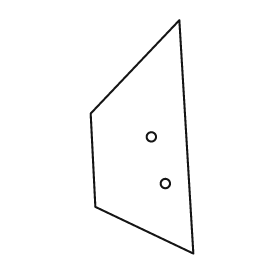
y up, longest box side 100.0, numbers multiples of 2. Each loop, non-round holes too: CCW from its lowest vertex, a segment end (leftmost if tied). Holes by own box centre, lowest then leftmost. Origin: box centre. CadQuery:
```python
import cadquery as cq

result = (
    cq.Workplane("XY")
    .moveTo(22.0, -50.0)
    .lineTo(16.0, 50.0)
    .lineTo(-22.0, 10.0)
    .lineTo(-20.0, -30.0)
    .close()
    .moveTo(10.0, -20.0)
    .circle(2.0)
    .moveTo(4.0, 0.0)
    .circle(2.0)
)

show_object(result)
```